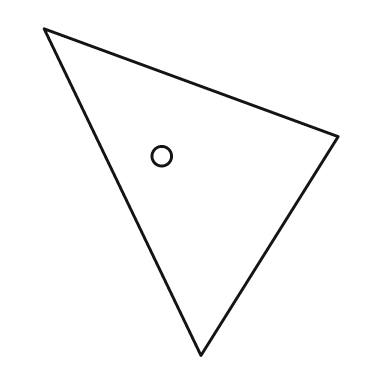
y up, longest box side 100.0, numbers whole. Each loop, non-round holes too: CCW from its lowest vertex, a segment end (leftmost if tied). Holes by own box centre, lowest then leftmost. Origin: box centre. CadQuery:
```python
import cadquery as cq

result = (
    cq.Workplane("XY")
    .moveTo(3.0, -50.0)
    .lineTo(45.0, 17.0)
    .lineTo(-45.0, 50.0)
    .close()
    .moveTo(-9.0, 11.0)
    .circle(3.0)
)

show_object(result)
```